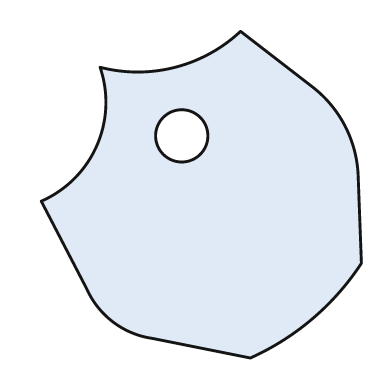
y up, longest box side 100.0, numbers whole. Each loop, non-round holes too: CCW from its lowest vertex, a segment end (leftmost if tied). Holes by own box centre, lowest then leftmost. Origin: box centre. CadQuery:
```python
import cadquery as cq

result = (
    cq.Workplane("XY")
    .moveTo(15.0, -50.0)
    .threePointArc((34.0, -38.0), (49.0, -21.0))
    .lineTo(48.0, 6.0)
    .threePointArc((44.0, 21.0), (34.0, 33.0))
    .lineTo(12.0, 50.0)
    .threePointArc((-8.0, 39.0), (-31.0, 39.0))
    .threePointArc((-32.0, 15.0), (-49.0, -2.0))
    .lineTo(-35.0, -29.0)
    .threePointArc((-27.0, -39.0), (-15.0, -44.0))
    .close()
    .moveTo(-6.0, 18.0)
    .circle(8.0)
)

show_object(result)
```